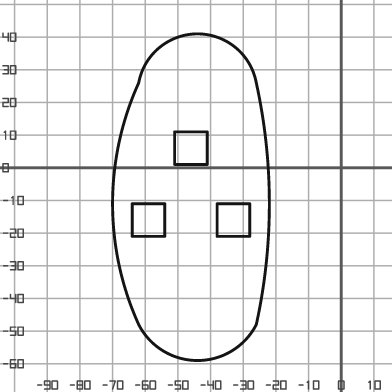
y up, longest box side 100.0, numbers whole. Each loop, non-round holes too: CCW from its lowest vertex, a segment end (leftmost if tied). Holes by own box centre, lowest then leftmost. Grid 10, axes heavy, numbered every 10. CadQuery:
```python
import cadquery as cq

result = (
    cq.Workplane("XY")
    .moveTo(-62.0, -48.0)
    .threePointArc((-44.0, -59.0), (-26.0, -48.0))
    .threePointArc((-22.0, -11.0), (-26.0, 26.0))
    .threePointArc((-44.0, 41.0), (-62.0, 26.0))
    .threePointArc((-70.0, -11.0), (-62.0, -48.0))
    .close()
    .moveTo(-64.0, -21.0)
    .lineTo(-54.0, -21.0)
    .lineTo(-54.0, -11.0)
    .lineTo(-64.0, -11.0)
    .close()
    .moveTo(-38.0, -21.0)
    .lineTo(-28.0, -21.0)
    .lineTo(-28.0, -11.0)
    .lineTo(-38.0, -11.0)
    .close()
    .moveTo(-51.0, 1.0)
    .lineTo(-41.0, 1.0)
    .lineTo(-41.0, 11.0)
    .lineTo(-51.0, 11.0)
    .close()
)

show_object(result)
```